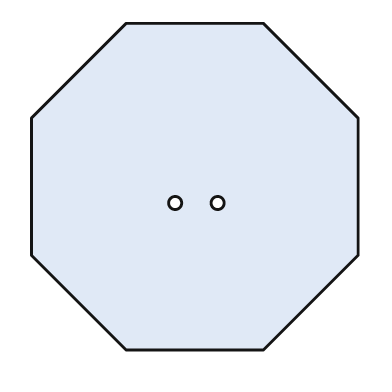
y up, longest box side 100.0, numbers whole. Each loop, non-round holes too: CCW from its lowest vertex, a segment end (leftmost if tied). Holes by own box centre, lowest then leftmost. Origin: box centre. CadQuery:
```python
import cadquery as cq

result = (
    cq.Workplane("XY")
    .moveTo(-21.0, -50.0)
    .lineTo(21.0, -50.0)
    .lineTo(50.0, -21.0)
    .lineTo(50.0, 21.0)
    .lineTo(21.0, 50.0)
    .lineTo(-21.0, 50.0)
    .lineTo(-50.0, 21.0)
    .lineTo(-50.0, -21.0)
    .close()
    .moveTo(-6.0, -5.0)
    .circle(2.0)
    .moveTo(7.0, -5.0)
    .circle(2.0)
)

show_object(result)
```